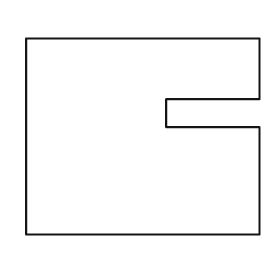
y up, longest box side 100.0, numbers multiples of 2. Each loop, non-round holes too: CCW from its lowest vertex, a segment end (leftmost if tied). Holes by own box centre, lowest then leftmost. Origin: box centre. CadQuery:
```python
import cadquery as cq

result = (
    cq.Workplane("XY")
    .moveTo(-50.0, -42.0)
    .lineTo(50.0, -42.0)
    .lineTo(50.0, 4.0)
    .lineTo(10.0, 4.0)
    .lineTo(10.0, 16.0)
    .lineTo(50.0, 16.0)
    .lineTo(50.0, 42.0)
    .lineTo(-50.0, 42.0)
    .close()
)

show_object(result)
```